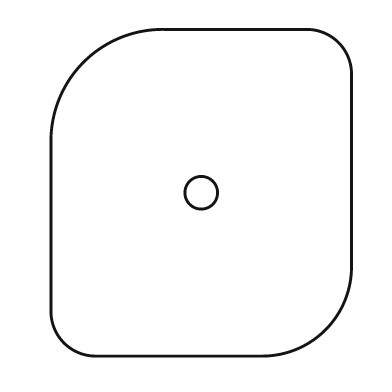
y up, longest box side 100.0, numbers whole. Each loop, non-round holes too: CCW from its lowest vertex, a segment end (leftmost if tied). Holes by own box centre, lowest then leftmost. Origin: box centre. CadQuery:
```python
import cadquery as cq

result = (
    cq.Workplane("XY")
    .moveTo(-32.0, -50.0)
    .lineTo(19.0, -50.0)
    .threePointArc((38.0, -42.0), (46.0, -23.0))
    .lineTo(46.0, 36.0)
    .threePointArc((42.0, 46.0), (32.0, 50.0))
    .lineTo(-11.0, 50.0)
    .threePointArc((-36.0, 40.0), (-46.0, 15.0))
    .lineTo(-46.0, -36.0)
    .threePointArc((-42.0, -46.0), (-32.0, -50.0))
    .close()
    .moveTo(0.0, 0.0)
    .circle(5.0)
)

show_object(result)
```